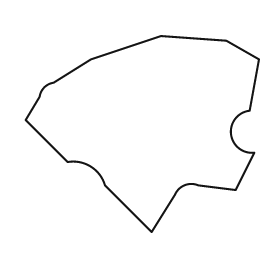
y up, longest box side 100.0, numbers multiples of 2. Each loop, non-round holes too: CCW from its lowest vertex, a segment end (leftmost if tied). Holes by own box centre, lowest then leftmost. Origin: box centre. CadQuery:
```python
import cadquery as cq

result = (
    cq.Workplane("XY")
    .moveTo(4.0, -42.0)
    .lineTo(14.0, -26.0)
    .threePointArc((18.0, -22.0), (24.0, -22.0))
    .lineTo(40.0, -24.0)
    .lineTo(48.0, -8.0)
    .threePointArc((38.0, 0.0), (46.0, 10.0))
    .lineTo(50.0, 32.0)
    .lineTo(36.0, 40.0)
    .lineTo(8.0, 42.0)
    .lineTo(-22.0, 32.0)
    .lineTo(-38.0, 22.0)
    .threePointArc((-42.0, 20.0), (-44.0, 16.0))
    .lineTo(-50.0, 6.0)
    .lineTo(-32.0, -12.0)
    .threePointArc((-22.0, -14.0), (-16.0, -22.0))
    .close()
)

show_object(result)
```